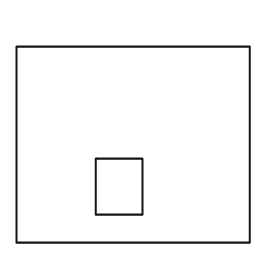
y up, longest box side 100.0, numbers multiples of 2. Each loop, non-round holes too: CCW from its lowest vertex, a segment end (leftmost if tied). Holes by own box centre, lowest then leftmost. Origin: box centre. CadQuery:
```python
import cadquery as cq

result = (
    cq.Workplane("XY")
    .moveTo(-50.0, -42.0)
    .lineTo(50.0, -42.0)
    .lineTo(50.0, 42.0)
    .lineTo(-50.0, 42.0)
    .close()
    .moveTo(-16.0, -30.0)
    .lineTo(4.0, -30.0)
    .lineTo(4.0, -6.0)
    .lineTo(-16.0, -6.0)
    .close()
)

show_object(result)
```